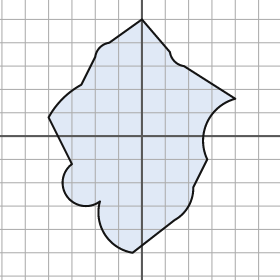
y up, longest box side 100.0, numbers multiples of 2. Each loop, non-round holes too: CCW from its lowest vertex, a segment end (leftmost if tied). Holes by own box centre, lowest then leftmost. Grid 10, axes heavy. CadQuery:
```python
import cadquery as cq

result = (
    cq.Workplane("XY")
    .moveTo(-4.0, -50.0)
    .lineTo(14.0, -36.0)
    .threePointArc((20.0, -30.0), (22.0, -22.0))
    .lineTo(28.0, -10.0)
    .threePointArc((28.0, 6.0), (40.0, 16.0))
    .lineTo(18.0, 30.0)
    .threePointArc((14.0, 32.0), (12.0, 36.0))
    .lineTo(0.0, 50.0)
    .lineTo(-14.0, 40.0)
    .threePointArc((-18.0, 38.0), (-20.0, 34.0))
    .lineTo(-26.0, 22.0)
    .threePointArc((-34.0, 16.0), (-40.0, 8.0))
    .lineTo(-30.0, -12.0)
    .threePointArc((-32.0, -26.0), (-18.0, -28.0))
    .threePointArc((-16.0, -42.0), (-4.0, -50.0))
    .close()
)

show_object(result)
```